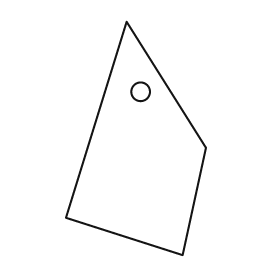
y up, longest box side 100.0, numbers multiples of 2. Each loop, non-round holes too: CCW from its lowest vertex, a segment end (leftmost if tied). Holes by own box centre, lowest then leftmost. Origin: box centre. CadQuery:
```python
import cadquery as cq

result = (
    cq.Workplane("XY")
    .moveTo(20.0, -50.0)
    .lineTo(30.0, -4.0)
    .lineTo(-4.0, 50.0)
    .lineTo(-30.0, -34.0)
    .close()
    .moveTo(2.0, 20.0)
    .circle(4.0)
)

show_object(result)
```